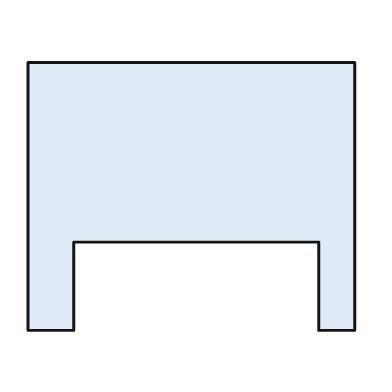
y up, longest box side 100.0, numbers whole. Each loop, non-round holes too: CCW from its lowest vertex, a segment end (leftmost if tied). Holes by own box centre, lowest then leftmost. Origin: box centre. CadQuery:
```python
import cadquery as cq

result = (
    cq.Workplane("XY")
    .moveTo(-50.0, -41.0)
    .lineTo(-36.0, -41.0)
    .lineTo(-36.0, -14.0)
    .lineTo(39.0, -14.0)
    .lineTo(39.0, -41.0)
    .lineTo(50.0, -41.0)
    .lineTo(50.0, 41.0)
    .lineTo(-50.0, 41.0)
    .close()
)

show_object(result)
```